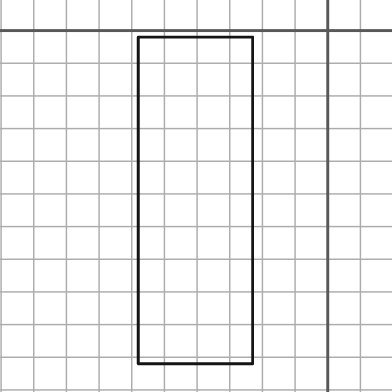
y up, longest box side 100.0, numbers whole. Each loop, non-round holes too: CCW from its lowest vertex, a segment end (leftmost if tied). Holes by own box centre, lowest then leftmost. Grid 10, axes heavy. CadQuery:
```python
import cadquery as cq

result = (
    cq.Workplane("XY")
    .moveTo(-58.0, -102.0)
    .lineTo(-23.0, -102.0)
    .lineTo(-23.0, -2.0)
    .lineTo(-58.0, -2.0)
    .close()
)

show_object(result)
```